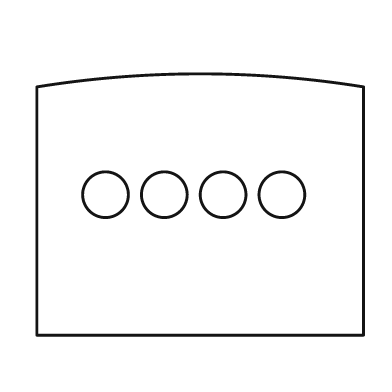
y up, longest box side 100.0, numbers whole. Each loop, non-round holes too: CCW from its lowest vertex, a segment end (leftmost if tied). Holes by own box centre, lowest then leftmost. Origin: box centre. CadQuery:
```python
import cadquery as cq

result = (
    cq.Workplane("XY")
    .moveTo(-50.0, -40.0)
    .lineTo(50.0, -40.0)
    .lineTo(50.0, 36.0)
    .threePointArc((0.0, 40.0), (-50.0, 36.0))
    .close()
    .moveTo(-29.0, 3.0)
    .circle(7.0)
    .moveTo(-11.0, 3.0)
    .circle(7.0)
    .moveTo(7.0, 3.0)
    .circle(7.0)
    .moveTo(25.0, 3.0)
    .circle(7.0)
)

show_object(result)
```